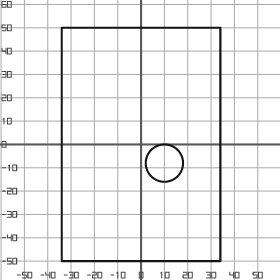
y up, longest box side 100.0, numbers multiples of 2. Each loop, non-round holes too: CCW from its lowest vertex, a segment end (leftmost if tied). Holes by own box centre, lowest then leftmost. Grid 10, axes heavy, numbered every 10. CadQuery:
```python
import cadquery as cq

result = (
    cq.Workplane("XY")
    .moveTo(-34.0, -50.0)
    .lineTo(34.0, -50.0)
    .lineTo(34.0, 50.0)
    .lineTo(-34.0, 50.0)
    .close()
    .moveTo(10.0, -8.0)
    .circle(8.0)
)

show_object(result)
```